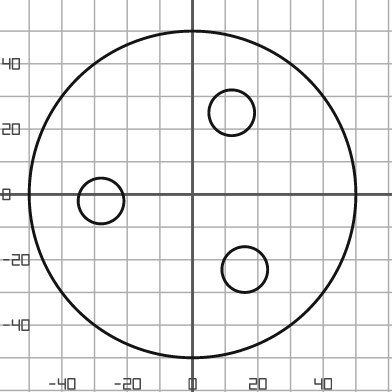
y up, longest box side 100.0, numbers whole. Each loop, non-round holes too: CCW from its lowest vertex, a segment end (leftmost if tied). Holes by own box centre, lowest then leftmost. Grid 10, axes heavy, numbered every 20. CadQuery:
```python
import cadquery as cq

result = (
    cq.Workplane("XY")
    .moveTo(0.0, 0.0)
    .circle(50.0)
    .moveTo(16.0, -23.0)
    .circle(7.0)
    .moveTo(-28.0, -2.0)
    .circle(7.0)
    .moveTo(12.0, 25.0)
    .circle(7.0)
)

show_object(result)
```